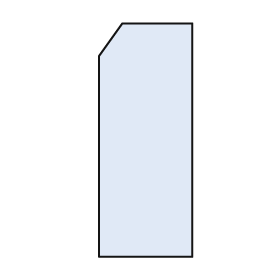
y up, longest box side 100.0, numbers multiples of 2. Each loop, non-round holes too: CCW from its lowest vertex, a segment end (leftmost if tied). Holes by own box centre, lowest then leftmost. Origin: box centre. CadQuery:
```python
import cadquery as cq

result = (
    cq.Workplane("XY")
    .moveTo(-20.0, -50.0)
    .lineTo(20.0, -50.0)
    .lineTo(20.0, 50.0)
    .lineTo(-10.0, 50.0)
    .lineTo(-20.0, 36.0)
    .close()
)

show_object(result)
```